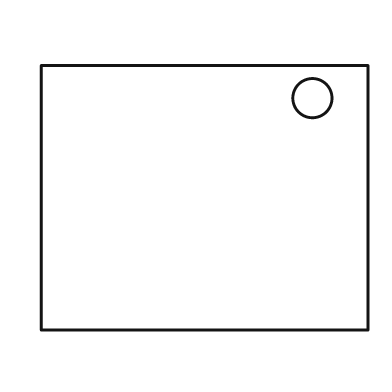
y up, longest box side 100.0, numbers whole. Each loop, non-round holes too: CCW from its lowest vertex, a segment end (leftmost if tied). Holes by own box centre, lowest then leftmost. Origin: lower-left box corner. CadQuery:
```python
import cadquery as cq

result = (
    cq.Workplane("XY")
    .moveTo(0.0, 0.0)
    .lineTo(100.0, 0.0)
    .lineTo(100.0, 81.0)
    .lineTo(0.0, 81.0)
    .close()
    .moveTo(83.0, 71.0)
    .circle(6.0)
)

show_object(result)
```